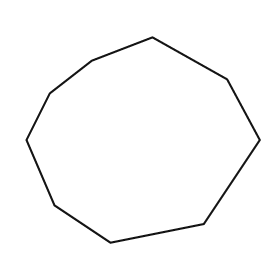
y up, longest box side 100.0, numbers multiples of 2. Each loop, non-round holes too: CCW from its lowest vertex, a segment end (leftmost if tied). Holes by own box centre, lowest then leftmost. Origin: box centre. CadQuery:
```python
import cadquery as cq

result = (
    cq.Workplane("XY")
    .moveTo(-14.0, -44.0)
    .lineTo(26.0, -36.0)
    .lineTo(50.0, 0.0)
    .lineTo(36.0, 26.0)
    .lineTo(4.0, 44.0)
    .lineTo(-22.0, 34.0)
    .lineTo(-40.0, 20.0)
    .lineTo(-50.0, 0.0)
    .lineTo(-38.0, -28.0)
    .close()
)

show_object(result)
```